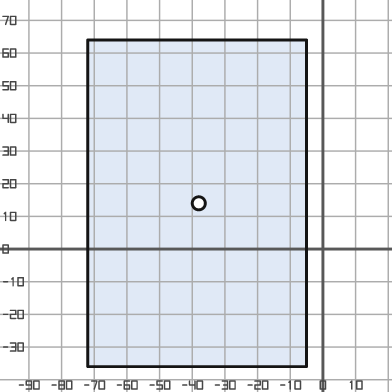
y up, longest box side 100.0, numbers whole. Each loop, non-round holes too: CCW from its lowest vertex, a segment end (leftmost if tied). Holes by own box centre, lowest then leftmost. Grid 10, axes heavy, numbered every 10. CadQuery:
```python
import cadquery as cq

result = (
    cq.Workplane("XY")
    .moveTo(-72.0, -36.0)
    .lineTo(-5.0, -36.0)
    .lineTo(-5.0, 64.0)
    .lineTo(-72.0, 64.0)
    .close()
    .moveTo(-38.0, 14.0)
    .circle(2.0)
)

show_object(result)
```